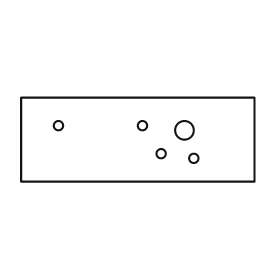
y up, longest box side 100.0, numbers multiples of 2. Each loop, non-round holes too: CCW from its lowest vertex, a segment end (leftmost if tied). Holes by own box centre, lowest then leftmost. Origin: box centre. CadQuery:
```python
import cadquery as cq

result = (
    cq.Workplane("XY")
    .moveTo(-50.0, -18.0)
    .lineTo(50.0, -18.0)
    .lineTo(50.0, 18.0)
    .lineTo(-50.0, 18.0)
    .close()
    .moveTo(24.0, -8.0)
    .circle(2.0)
    .moveTo(10.0, -6.0)
    .circle(2.0)
    .moveTo(20.0, 4.0)
    .circle(4.0)
    .moveTo(-34.0, 6.0)
    .circle(2.0)
    .moveTo(2.0, 6.0)
    .circle(2.0)
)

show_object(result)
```